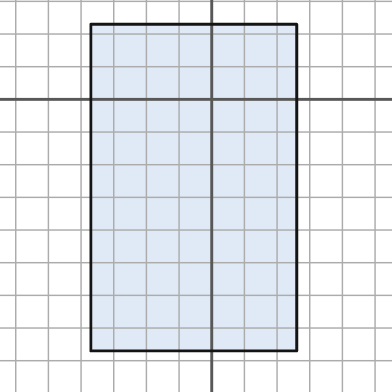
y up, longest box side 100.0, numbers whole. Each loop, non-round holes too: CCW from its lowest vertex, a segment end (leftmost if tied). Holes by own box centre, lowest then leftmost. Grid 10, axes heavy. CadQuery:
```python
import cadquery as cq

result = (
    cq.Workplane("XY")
    .moveTo(-37.0, -77.0)
    .lineTo(26.0, -77.0)
    .lineTo(26.0, 23.0)
    .lineTo(-37.0, 23.0)
    .close()
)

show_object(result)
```